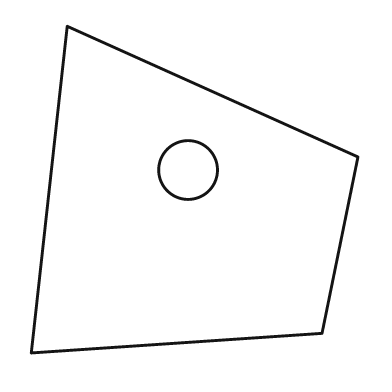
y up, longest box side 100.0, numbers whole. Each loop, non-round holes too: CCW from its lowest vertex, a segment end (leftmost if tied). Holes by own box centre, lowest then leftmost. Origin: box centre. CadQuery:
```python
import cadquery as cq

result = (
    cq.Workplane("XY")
    .moveTo(-50.0, -50.0)
    .lineTo(39.0, -44.0)
    .lineTo(50.0, 10.0)
    .lineTo(-39.0, 50.0)
    .close()
    .moveTo(-2.0, 6.0)
    .circle(9.0)
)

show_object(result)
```